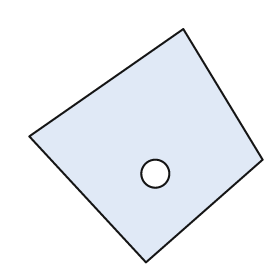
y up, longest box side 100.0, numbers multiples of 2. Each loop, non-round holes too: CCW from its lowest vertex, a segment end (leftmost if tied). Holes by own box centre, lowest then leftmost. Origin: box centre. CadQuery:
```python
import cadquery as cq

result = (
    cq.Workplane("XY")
    .moveTo(0.0, -50.0)
    .lineTo(50.0, -6.0)
    .lineTo(16.0, 50.0)
    .lineTo(-50.0, 4.0)
    .close()
    .moveTo(4.0, -12.0)
    .circle(6.0)
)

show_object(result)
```